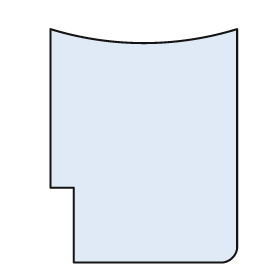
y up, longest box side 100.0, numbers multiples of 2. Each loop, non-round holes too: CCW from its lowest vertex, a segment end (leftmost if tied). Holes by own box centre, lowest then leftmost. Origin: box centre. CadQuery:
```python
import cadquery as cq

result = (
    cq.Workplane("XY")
    .moveTo(-30.0, -50.0)
    .lineTo(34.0, -50.0)
    .threePointArc((38.0, -48.0), (40.0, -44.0))
    .lineTo(40.0, 50.0)
    .threePointArc((0.0, 44.0), (-40.0, 50.0))
    .lineTo(-40.0, -18.0)
    .lineTo(-30.0, -18.0)
    .close()
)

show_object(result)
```